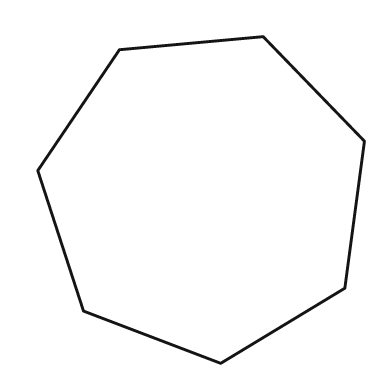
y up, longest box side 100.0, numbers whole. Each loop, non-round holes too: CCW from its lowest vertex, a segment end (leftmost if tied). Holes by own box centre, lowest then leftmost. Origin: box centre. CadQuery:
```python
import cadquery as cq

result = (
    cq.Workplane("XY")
    .moveTo(6.0, -50.0)
    .lineTo(44.0, -27.0)
    .lineTo(50.0, 18.0)
    .lineTo(19.0, 50.0)
    .lineTo(-25.0, 46.0)
    .lineTo(-50.0, 9.0)
    .lineTo(-36.0, -34.0)
    .close()
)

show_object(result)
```